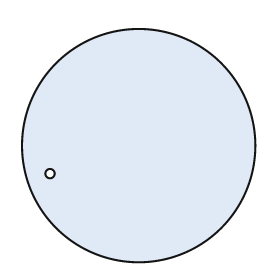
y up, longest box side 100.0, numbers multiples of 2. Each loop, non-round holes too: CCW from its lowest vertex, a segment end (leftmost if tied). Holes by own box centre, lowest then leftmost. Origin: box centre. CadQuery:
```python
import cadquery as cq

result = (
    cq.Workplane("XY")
    .moveTo(0.0, 0.0)
    .circle(50.0)
    .moveTo(-38.0, -12.0)
    .circle(2.0)
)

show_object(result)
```